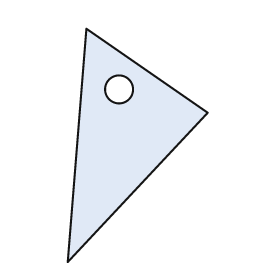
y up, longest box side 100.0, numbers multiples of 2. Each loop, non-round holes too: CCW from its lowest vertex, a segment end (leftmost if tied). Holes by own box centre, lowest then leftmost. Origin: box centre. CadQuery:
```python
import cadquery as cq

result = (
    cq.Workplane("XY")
    .moveTo(-30.0, -50.0)
    .lineTo(30.0, 14.0)
    .lineTo(-22.0, 50.0)
    .close()
    .moveTo(-8.0, 24.0)
    .circle(6.0)
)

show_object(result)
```